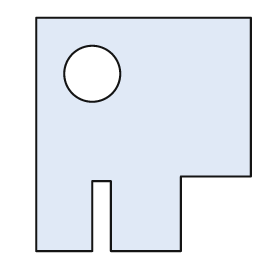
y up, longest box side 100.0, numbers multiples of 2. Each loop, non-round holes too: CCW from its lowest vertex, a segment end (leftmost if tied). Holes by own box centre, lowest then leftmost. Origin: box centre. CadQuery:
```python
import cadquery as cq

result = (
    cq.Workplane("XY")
    .moveTo(-46.0, -50.0)
    .lineTo(-22.0, -50.0)
    .lineTo(-22.0, -20.0)
    .lineTo(-14.0, -20.0)
    .lineTo(-14.0, -50.0)
    .lineTo(16.0, -50.0)
    .lineTo(16.0, -18.0)
    .lineTo(46.0, -18.0)
    .lineTo(46.0, 50.0)
    .lineTo(-46.0, 50.0)
    .close()
    .moveTo(-22.0, 26.0)
    .circle(12.0)
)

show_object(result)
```